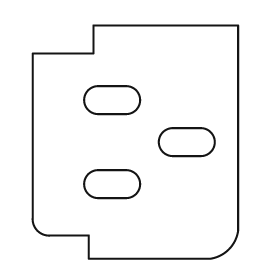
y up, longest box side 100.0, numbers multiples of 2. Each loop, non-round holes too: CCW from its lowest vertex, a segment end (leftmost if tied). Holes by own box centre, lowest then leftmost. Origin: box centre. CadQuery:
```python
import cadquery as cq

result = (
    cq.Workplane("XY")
    .moveTo(-20.0, -50.0)
    .lineTo(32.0, -50.0)
    .threePointArc((40.0, -46.0), (44.0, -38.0))
    .lineTo(44.0, 50.0)
    .lineTo(-18.0, 50.0)
    .lineTo(-18.0, 38.0)
    .lineTo(-44.0, 38.0)
    .lineTo(-44.0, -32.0)
    .threePointArc((-42.0, -38.0), (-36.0, -40.0))
    .lineTo(-20.0, -40.0)
    .close()
    .moveTo(-16.0, -24.0)
    .lineTo(-4.0, -24.0)
    .threePointArc((2.0, -18.0), (-4.0, -12.0))
    .lineTo(-16.0, -12.0)
    .threePointArc((-22.0, -18.0), (-16.0, -24.0))
    .close()
    .moveTo(16.0, -6.0)
    .lineTo(28.0, -6.0)
    .threePointArc((34.0, 0.0), (28.0, 6.0))
    .lineTo(16.0, 6.0)
    .threePointArc((10.0, 0.0), (16.0, -6.0))
    .close()
    .moveTo(-16.0, 12.0)
    .lineTo(-4.0, 12.0)
    .threePointArc((2.0, 18.0), (-4.0, 24.0))
    .lineTo(-16.0, 24.0)
    .threePointArc((-22.0, 18.0), (-16.0, 12.0))
    .close()
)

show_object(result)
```